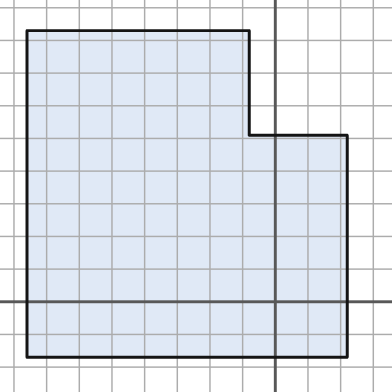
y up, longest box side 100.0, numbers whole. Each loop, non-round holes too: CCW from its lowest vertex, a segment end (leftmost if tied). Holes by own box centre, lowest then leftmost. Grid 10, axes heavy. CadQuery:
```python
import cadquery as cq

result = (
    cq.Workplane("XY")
    .moveTo(-76.0, -17.0)
    .lineTo(22.0, -17.0)
    .lineTo(22.0, 51.0)
    .lineTo(-8.0, 51.0)
    .lineTo(-8.0, 83.0)
    .lineTo(-76.0, 83.0)
    .close()
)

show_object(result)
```